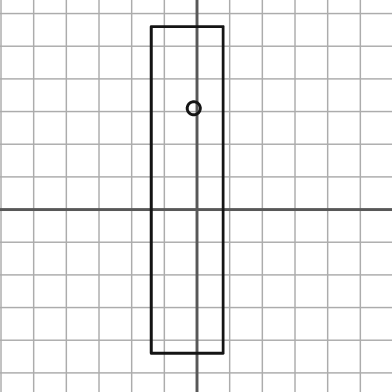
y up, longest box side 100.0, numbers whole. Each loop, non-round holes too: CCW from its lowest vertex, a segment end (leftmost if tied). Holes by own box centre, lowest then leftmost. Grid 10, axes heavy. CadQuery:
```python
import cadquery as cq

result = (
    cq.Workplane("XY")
    .moveTo(-14.0, -44.0)
    .lineTo(8.0, -44.0)
    .lineTo(8.0, 56.0)
    .lineTo(-14.0, 56.0)
    .close()
    .moveTo(-1.0, 31.0)
    .circle(2.0)
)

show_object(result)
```